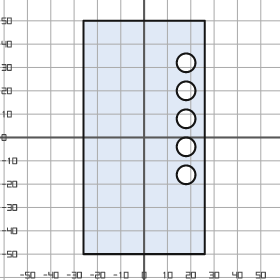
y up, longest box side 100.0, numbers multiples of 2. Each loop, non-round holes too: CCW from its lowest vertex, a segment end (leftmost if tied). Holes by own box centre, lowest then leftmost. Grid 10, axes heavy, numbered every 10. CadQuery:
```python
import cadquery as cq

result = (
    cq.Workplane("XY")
    .moveTo(-26.0, -50.0)
    .lineTo(26.0, -50.0)
    .lineTo(26.0, 50.0)
    .lineTo(-26.0, 50.0)
    .close()
    .moveTo(18.0, -16.0)
    .circle(4.0)
    .moveTo(18.0, -4.0)
    .circle(4.0)
    .moveTo(18.0, 8.0)
    .circle(4.0)
    .moveTo(18.0, 20.0)
    .circle(4.0)
    .moveTo(18.0, 32.0)
    .circle(4.0)
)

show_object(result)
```